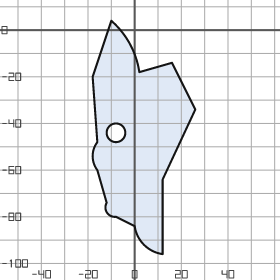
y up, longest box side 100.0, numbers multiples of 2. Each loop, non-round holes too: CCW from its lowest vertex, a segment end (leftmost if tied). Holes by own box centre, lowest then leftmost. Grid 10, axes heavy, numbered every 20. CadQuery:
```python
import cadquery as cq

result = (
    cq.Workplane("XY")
    .moveTo(12.0, -96.0)
    .lineTo(12.0, -64.0)
    .lineTo(26.0, -34.0)
    .lineTo(16.0, -14.0)
    .lineTo(2.0, -18.0)
    .threePointArc((-2.0, -6.0), (-10.0, 4.0))
    .lineTo(-18.0, -20.0)
    .lineTo(-16.0, -48.0)
    .threePointArc((-18.0, -54.0), (-16.0, -60.0))
    .lineTo(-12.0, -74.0)
    .threePointArc((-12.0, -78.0), (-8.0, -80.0))
    .lineTo(0.0, -84.0)
    .threePointArc((4.0, -92.0), (12.0, -96.0))
    .close()
    .moveTo(-8.0, -44.0)
    .circle(4.0)
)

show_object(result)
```